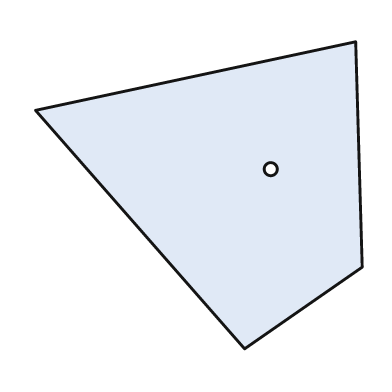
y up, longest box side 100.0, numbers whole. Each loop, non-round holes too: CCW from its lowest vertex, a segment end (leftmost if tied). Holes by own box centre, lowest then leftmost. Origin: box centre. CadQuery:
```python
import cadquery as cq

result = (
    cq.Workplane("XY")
    .moveTo(14.0, -47.0)
    .lineTo(50.0, -22.0)
    .lineTo(48.0, 47.0)
    .lineTo(-50.0, 26.0)
    .close()
    .moveTo(22.0, 8.0)
    .circle(2.0)
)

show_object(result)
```